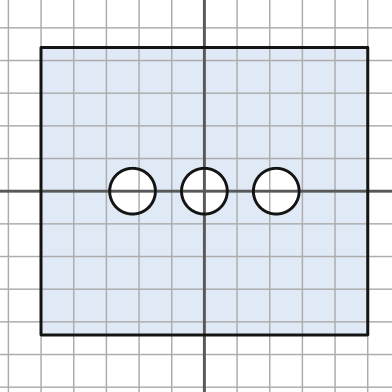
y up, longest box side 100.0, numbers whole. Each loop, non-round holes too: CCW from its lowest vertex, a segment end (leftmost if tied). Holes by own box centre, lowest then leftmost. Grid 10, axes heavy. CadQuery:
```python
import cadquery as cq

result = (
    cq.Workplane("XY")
    .moveTo(-50.0, -44.0)
    .lineTo(50.0, -44.0)
    .lineTo(50.0, 44.0)
    .lineTo(-50.0, 44.0)
    .close()
    .moveTo(-22.0, 0.0)
    .circle(7.0)
    .moveTo(0.0, 0.0)
    .circle(7.0)
    .moveTo(22.0, 0.0)
    .circle(7.0)
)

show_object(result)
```